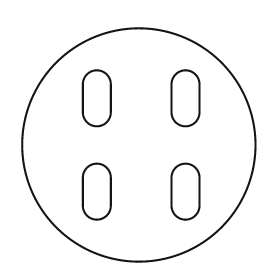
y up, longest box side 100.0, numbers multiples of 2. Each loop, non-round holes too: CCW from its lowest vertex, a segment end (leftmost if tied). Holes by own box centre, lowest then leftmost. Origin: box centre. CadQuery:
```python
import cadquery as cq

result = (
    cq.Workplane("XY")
    .moveTo(0.0, 0.0)
    .circle(50.0)
    .moveTo(-24.0, -26.0)
    .threePointArc((-18.0, -32.0), (-12.0, -26.0))
    .lineTo(-12.0, -14.0)
    .threePointArc((-18.0, -8.0), (-24.0, -14.0))
    .close()
    .moveTo(14.0, -26.0)
    .threePointArc((20.0, -32.0), (26.0, -26.0))
    .lineTo(26.0, -14.0)
    .threePointArc((20.0, -8.0), (14.0, -14.0))
    .close()
    .moveTo(-24.0, 14.0)
    .threePointArc((-18.0, 8.0), (-12.0, 14.0))
    .lineTo(-12.0, 26.0)
    .threePointArc((-18.0, 32.0), (-24.0, 26.0))
    .close()
    .moveTo(14.0, 14.0)
    .threePointArc((20.0, 8.0), (26.0, 14.0))
    .lineTo(26.0, 26.0)
    .threePointArc((20.0, 32.0), (14.0, 26.0))
    .close()
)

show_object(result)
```